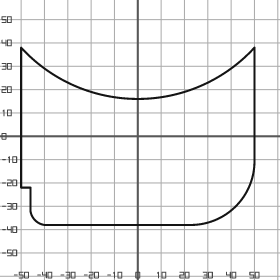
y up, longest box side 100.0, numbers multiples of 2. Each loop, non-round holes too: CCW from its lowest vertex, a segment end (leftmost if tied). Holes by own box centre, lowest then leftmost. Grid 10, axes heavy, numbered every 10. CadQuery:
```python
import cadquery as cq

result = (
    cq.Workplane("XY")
    .moveTo(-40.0, -38.0)
    .lineTo(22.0, -38.0)
    .threePointArc((42.0, -30.0), (50.0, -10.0))
    .lineTo(50.0, 38.0)
    .threePointArc((0.0, 16.0), (-50.0, 38.0))
    .lineTo(-50.0, -22.0)
    .lineTo(-46.0, -22.0)
    .lineTo(-46.0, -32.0)
    .threePointArc((-44.0, -36.0), (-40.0, -38.0))
    .close()
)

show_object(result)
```